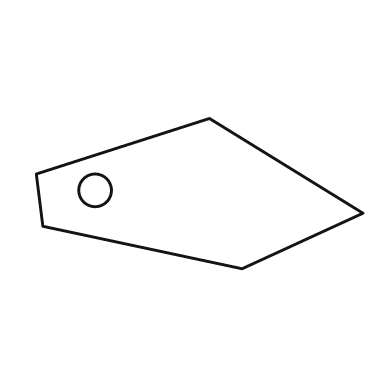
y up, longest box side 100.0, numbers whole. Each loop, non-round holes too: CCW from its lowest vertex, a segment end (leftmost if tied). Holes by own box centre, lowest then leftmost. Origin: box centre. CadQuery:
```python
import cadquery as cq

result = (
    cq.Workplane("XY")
    .moveTo(13.0, -23.0)
    .lineTo(50.0, -6.0)
    .lineTo(3.0, 23.0)
    .lineTo(-50.0, 6.0)
    .lineTo(-48.0, -10.0)
    .close()
    .moveTo(-32.0, 1.0)
    .circle(5.0)
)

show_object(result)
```